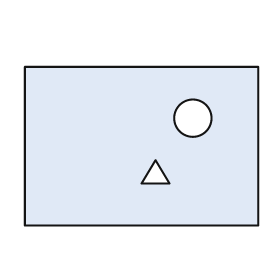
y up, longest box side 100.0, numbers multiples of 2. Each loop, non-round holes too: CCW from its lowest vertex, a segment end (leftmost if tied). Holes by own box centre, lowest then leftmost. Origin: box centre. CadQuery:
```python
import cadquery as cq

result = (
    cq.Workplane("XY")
    .moveTo(-50.0, -34.0)
    .lineTo(50.0, -34.0)
    .lineTo(50.0, 34.0)
    .lineTo(-50.0, 34.0)
    .close()
    .moveTo(0.0, -16.0)
    .lineTo(12.0, -16.0)
    .lineTo(6.0, -6.0)
    .close()
    .moveTo(22.0, 12.0)
    .circle(8.0)
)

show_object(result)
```